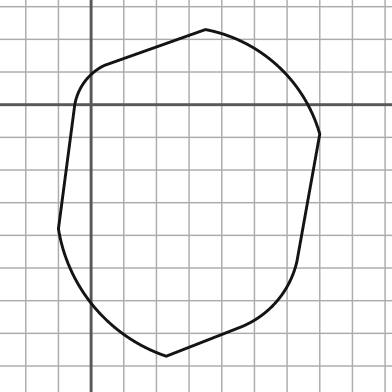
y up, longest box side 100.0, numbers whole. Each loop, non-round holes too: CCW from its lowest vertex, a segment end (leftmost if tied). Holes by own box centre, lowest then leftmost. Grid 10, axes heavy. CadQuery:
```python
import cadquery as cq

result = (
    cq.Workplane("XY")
    .moveTo(23.0, -77.0)
    .lineTo(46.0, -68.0)
    .threePointArc((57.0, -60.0), (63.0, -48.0))
    .lineTo(70.0, -9.0)
    .threePointArc((57.0, 12.0), (35.0, 23.0))
    .lineTo(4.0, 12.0)
    .threePointArc((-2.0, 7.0), (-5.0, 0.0))
    .lineTo(-10.0, -38.0)
    .threePointArc((1.0, -62.0), (23.0, -77.0))
    .close()
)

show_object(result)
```